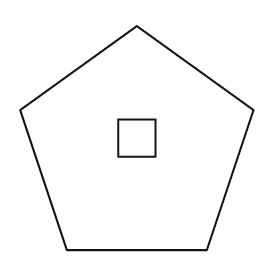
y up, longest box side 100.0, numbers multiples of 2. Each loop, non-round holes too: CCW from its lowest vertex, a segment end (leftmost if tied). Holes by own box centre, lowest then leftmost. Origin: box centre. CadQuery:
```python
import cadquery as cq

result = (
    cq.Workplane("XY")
    .moveTo(-30.0, -48.0)
    .lineTo(30.0, -48.0)
    .lineTo(50.0, 12.0)
    .lineTo(0.0, 48.0)
    .lineTo(-50.0, 12.0)
    .close()
    .moveTo(-8.0, -8.0)
    .lineTo(8.0, -8.0)
    .lineTo(8.0, 8.0)
    .lineTo(-8.0, 8.0)
    .close()
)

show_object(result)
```